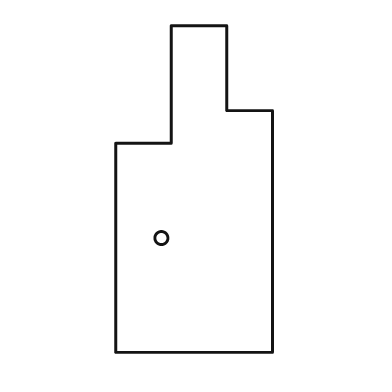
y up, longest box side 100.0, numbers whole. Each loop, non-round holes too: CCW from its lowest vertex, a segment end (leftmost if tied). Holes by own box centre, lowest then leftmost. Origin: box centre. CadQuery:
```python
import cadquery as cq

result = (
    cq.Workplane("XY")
    .moveTo(-24.0, -50.0)
    .lineTo(24.0, -50.0)
    .lineTo(24.0, 24.0)
    .lineTo(10.0, 24.0)
    .lineTo(10.0, 50.0)
    .lineTo(-7.0, 50.0)
    .lineTo(-7.0, 14.0)
    .lineTo(-24.0, 14.0)
    .close()
    .moveTo(-10.0, -15.0)
    .circle(2.0)
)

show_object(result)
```